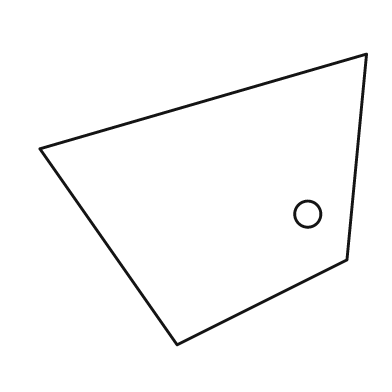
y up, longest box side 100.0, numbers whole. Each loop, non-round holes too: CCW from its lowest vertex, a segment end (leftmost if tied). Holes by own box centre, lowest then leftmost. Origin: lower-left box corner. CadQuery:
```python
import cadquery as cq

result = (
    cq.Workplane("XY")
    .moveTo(42.0, 0.0)
    .lineTo(94.0, 26.0)
    .lineTo(100.0, 89.0)
    .lineTo(0.0, 60.0)
    .close()
    .moveTo(82.0, 40.0)
    .circle(4.0)
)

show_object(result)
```